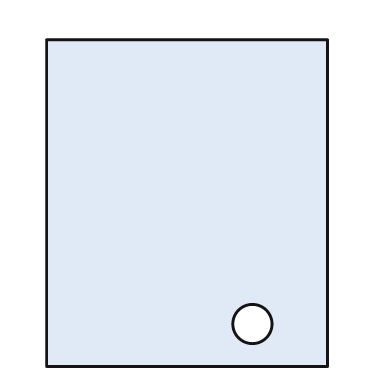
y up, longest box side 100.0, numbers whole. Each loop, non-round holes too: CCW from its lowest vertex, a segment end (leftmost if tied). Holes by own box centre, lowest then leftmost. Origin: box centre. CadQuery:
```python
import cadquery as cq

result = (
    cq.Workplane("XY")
    .moveTo(-43.0, -50.0)
    .lineTo(43.0, -50.0)
    .lineTo(43.0, 50.0)
    .lineTo(-43.0, 50.0)
    .close()
    .moveTo(20.0, -37.0)
    .circle(6.0)
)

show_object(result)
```